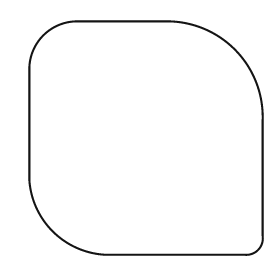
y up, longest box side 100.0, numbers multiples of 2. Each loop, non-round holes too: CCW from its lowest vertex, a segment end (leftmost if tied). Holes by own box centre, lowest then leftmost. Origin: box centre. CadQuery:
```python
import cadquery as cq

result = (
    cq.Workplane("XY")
    .moveTo(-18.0, -50.0)
    .lineTo(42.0, -50.0)
    .threePointArc((48.0, -48.0), (50.0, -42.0))
    .lineTo(50.0, 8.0)
    .threePointArc((38.0, 38.0), (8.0, 50.0))
    .lineTo(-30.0, 50.0)
    .threePointArc((-44.0, 44.0), (-50.0, 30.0))
    .lineTo(-50.0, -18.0)
    .threePointArc((-40.0, -40.0), (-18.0, -50.0))
    .close()
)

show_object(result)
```